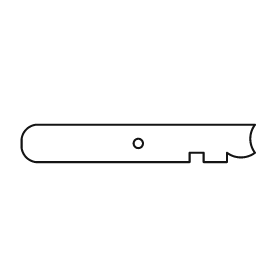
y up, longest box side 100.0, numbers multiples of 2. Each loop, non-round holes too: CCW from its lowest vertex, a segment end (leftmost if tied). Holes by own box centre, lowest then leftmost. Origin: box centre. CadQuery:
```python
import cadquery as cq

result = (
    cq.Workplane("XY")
    .moveTo(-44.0, -8.0)
    .lineTo(22.0, -8.0)
    .lineTo(22.0, -4.0)
    .lineTo(28.0, -4.0)
    .lineTo(28.0, -8.0)
    .lineTo(38.0, -8.0)
    .lineTo(38.0, -4.0)
    .threePointArc((44.0, -6.0), (50.0, -4.0))
    .threePointArc((48.0, 2.0), (50.0, 8.0))
    .lineTo(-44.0, 8.0)
    .threePointArc((-48.0, 6.0), (-50.0, 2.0))
    .lineTo(-50.0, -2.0)
    .threePointArc((-48.0, -6.0), (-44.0, -8.0))
    .close()
    .moveTo(0.0, 0.0)
    .circle(2.0)
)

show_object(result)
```